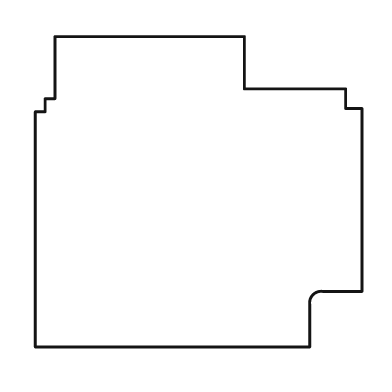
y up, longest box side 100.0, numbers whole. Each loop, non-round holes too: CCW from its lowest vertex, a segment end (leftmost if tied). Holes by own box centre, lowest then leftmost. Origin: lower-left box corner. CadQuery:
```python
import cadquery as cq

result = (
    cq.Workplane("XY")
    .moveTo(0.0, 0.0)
    .lineTo(84.0, 0.0)
    .lineTo(84.0, 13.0)
    .threePointArc((85.0, 16.0), (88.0, 17.0))
    .lineTo(100.0, 17.0)
    .lineTo(100.0, 73.0)
    .lineTo(95.0, 73.0)
    .lineTo(95.0, 79.0)
    .lineTo(64.0, 79.0)
    .lineTo(64.0, 95.0)
    .lineTo(6.0, 95.0)
    .lineTo(6.0, 76.0)
    .lineTo(3.0, 76.0)
    .lineTo(3.0, 72.0)
    .lineTo(0.0, 72.0)
    .close()
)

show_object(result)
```